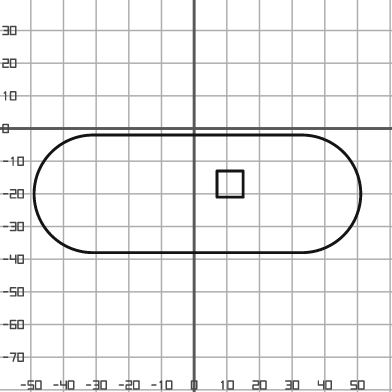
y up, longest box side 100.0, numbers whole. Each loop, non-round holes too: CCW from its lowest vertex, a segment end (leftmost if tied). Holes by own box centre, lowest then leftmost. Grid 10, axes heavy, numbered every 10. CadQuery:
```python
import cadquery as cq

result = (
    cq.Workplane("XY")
    .moveTo(-31.0, -38.0)
    .lineTo(33.0, -38.0)
    .threePointArc((51.0, -20.0), (33.0, -2.0))
    .lineTo(-31.0, -2.0)
    .threePointArc((-49.0, -20.0), (-31.0, -38.0))
    .close()
    .moveTo(7.0, -21.0)
    .lineTo(15.0, -21.0)
    .lineTo(15.0, -13.0)
    .lineTo(7.0, -13.0)
    .close()
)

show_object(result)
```